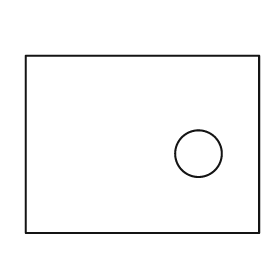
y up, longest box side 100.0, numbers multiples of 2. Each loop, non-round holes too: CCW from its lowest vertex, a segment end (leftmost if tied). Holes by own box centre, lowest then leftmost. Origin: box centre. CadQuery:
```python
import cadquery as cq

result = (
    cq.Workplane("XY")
    .moveTo(-50.0, -38.0)
    .lineTo(50.0, -38.0)
    .lineTo(50.0, 38.0)
    .lineTo(-50.0, 38.0)
    .close()
    .moveTo(24.0, -4.0)
    .circle(10.0)
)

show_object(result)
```